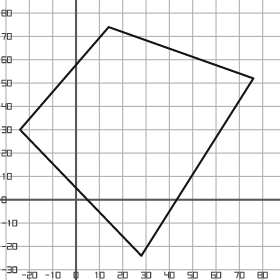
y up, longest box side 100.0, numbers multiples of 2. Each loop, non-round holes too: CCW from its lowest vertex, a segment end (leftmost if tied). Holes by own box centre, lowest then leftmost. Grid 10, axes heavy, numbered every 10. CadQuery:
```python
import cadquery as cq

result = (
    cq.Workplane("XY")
    .moveTo(28.0, -24.0)
    .lineTo(76.0, 52.0)
    .lineTo(14.0, 74.0)
    .lineTo(-24.0, 30.0)
    .close()
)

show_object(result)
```